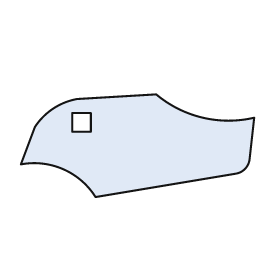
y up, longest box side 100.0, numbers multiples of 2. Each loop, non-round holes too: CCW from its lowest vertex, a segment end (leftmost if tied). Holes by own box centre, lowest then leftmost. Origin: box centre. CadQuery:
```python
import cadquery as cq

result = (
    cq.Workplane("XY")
    .moveTo(-18.0, -22.0)
    .lineTo(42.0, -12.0)
    .threePointArc((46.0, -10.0), (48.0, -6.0))
    .lineTo(50.0, 12.0)
    .threePointArc((28.0, 12.0), (8.0, 22.0))
    .lineTo(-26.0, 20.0)
    .threePointArc((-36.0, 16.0), (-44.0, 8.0))
    .lineTo(-50.0, -8.0)
    .threePointArc((-32.0, -10.0), (-18.0, -22.0))
    .close()
    .moveTo(-28.0, 6.0)
    .lineTo(-20.0, 6.0)
    .lineTo(-20.0, 14.0)
    .lineTo(-28.0, 14.0)
    .close()
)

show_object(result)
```